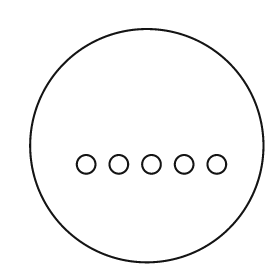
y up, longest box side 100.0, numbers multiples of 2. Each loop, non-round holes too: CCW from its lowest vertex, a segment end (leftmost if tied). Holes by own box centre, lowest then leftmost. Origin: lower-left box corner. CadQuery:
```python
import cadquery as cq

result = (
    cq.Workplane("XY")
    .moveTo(50.0, 50.0)
    .circle(50.0)
    .moveTo(24.0, 42.0)
    .circle(4.0)
    .moveTo(38.0, 42.0)
    .circle(4.0)
    .moveTo(52.0, 42.0)
    .circle(4.0)
    .moveTo(66.0, 42.0)
    .circle(4.0)
    .moveTo(80.0, 42.0)
    .circle(4.0)
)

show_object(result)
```